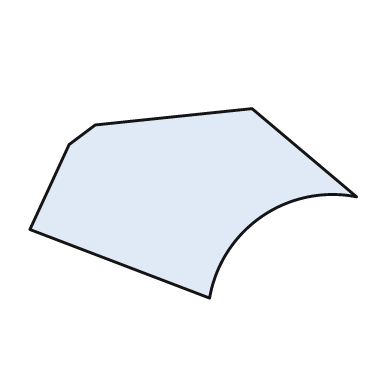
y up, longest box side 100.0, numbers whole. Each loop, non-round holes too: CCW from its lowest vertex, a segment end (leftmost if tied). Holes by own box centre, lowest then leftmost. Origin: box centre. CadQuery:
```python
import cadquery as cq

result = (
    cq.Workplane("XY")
    .moveTo(5.0, -29.0)
    .threePointArc((21.0, -4.0), (50.0, 2.0))
    .lineTo(18.0, 29.0)
    .lineTo(-30.0, 24.0)
    .lineTo(-38.0, 18.0)
    .lineTo(-50.0, -8.0)
    .close()
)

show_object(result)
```